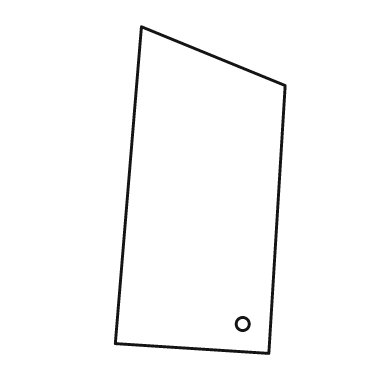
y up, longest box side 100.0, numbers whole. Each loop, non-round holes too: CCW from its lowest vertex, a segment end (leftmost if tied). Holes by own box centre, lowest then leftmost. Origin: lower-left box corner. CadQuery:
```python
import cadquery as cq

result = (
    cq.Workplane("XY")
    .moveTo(47.0, 0.0)
    .lineTo(52.0, 82.0)
    .lineTo(8.0, 100.0)
    .lineTo(0.0, 3.0)
    .close()
    .moveTo(39.0, 9.0)
    .circle(2.0)
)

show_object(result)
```